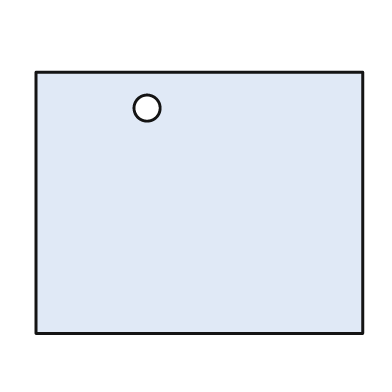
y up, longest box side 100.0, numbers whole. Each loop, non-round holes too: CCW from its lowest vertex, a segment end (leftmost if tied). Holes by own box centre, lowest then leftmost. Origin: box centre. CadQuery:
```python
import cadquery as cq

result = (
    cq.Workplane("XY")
    .moveTo(-50.0, -40.0)
    .lineTo(50.0, -40.0)
    .lineTo(50.0, 40.0)
    .lineTo(-50.0, 40.0)
    .close()
    .moveTo(-16.0, 29.0)
    .circle(4.0)
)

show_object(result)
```